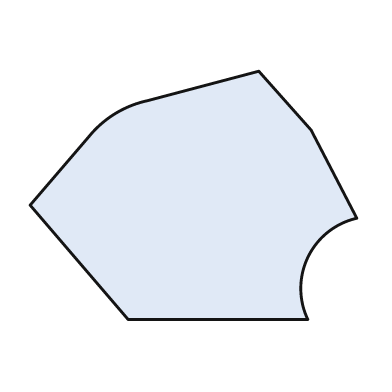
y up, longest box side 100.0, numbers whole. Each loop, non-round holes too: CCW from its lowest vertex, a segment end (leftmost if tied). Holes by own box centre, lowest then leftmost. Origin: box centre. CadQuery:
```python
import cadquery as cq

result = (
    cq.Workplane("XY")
    .moveTo(-20.0, -38.0)
    .lineTo(35.0, -38.0)
    .threePointArc((35.0, -19.0), (50.0, -7.0))
    .lineTo(36.0, 20.0)
    .lineTo(20.0, 38.0)
    .lineTo(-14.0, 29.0)
    .threePointArc((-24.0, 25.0), (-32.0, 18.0))
    .lineTo(-50.0, -3.0)
    .close()
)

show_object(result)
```